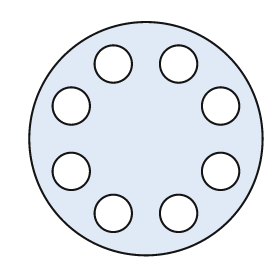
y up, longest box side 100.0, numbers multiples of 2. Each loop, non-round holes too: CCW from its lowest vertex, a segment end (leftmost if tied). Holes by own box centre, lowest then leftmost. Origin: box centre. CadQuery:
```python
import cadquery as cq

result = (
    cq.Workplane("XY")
    .moveTo(0.0, 0.0)
    .circle(50.0)
    .moveTo(-14.0, -32.0)
    .circle(8.0)
    .moveTo(14.0, -32.0)
    .circle(8.0)
    .moveTo(-32.0, -14.0)
    .circle(8.0)
    .moveTo(32.0, -14.0)
    .circle(8.0)
    .moveTo(-32.0, 14.0)
    .circle(8.0)
    .moveTo(32.0, 14.0)
    .circle(8.0)
    .moveTo(-14.0, 32.0)
    .circle(8.0)
    .moveTo(14.0, 32.0)
    .circle(8.0)
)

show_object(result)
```